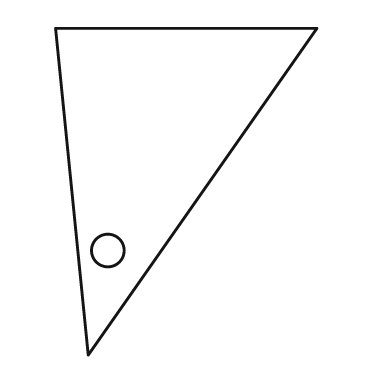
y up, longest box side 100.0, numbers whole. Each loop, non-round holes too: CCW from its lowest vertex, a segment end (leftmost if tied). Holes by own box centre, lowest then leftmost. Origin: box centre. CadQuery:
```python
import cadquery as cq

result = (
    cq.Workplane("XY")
    .moveTo(-30.0, -50.0)
    .lineTo(40.0, 50.0)
    .lineTo(-40.0, 50.0)
    .close()
    .moveTo(-24.0, -18.0)
    .circle(5.0)
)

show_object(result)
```